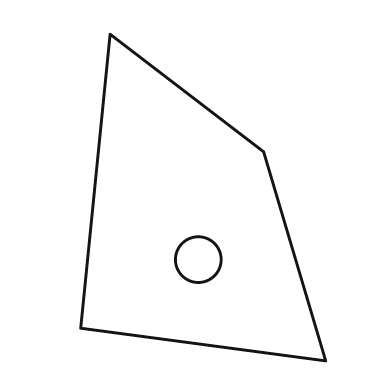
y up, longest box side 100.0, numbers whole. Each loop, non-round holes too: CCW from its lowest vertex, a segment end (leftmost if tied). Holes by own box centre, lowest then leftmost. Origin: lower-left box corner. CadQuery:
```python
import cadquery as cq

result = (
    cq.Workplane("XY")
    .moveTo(75.0, 0.0)
    .lineTo(56.0, 64.0)
    .lineTo(9.0, 100.0)
    .lineTo(0.0, 10.0)
    .close()
    .moveTo(36.0, 31.0)
    .circle(7.0)
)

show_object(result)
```